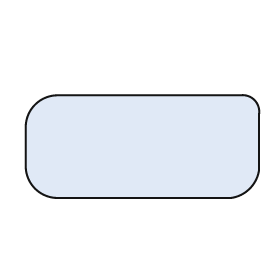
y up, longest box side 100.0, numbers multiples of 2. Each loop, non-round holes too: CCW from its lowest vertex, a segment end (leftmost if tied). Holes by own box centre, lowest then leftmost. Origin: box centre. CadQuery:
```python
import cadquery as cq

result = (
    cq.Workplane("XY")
    .moveTo(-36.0, -22.0)
    .lineTo(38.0, -22.0)
    .threePointArc((46.0, -18.0), (50.0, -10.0))
    .lineTo(50.0, 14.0)
    .threePointArc((48.0, 20.0), (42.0, 22.0))
    .lineTo(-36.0, 22.0)
    .threePointArc((-46.0, 18.0), (-50.0, 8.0))
    .lineTo(-50.0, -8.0)
    .threePointArc((-46.0, -18.0), (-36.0, -22.0))
    .close()
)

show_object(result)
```